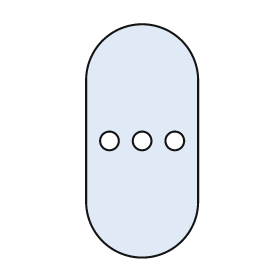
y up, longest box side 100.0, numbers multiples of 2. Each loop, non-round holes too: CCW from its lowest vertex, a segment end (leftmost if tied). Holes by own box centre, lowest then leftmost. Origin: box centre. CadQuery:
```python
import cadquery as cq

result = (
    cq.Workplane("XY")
    .moveTo(-24.0, -26.0)
    .threePointArc((0.0, -50.0), (24.0, -26.0))
    .lineTo(24.0, 26.0)
    .threePointArc((0.0, 50.0), (-24.0, 26.0))
    .close()
    .moveTo(-14.0, 0.0)
    .circle(4.0)
    .moveTo(0.0, 0.0)
    .circle(4.0)
    .moveTo(14.0, 0.0)
    .circle(4.0)
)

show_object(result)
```